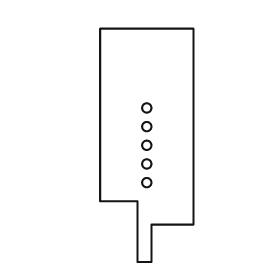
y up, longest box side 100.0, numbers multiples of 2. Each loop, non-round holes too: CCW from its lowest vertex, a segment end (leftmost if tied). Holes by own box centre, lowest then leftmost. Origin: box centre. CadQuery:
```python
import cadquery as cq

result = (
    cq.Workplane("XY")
    .moveTo(-4.0, -50.0)
    .lineTo(2.0, -50.0)
    .lineTo(2.0, -34.0)
    .lineTo(20.0, -34.0)
    .lineTo(20.0, 50.0)
    .lineTo(-20.0, 50.0)
    .lineTo(-20.0, -24.0)
    .lineTo(-4.0, -24.0)
    .close()
    .moveTo(0.0, -16.0)
    .circle(2.0)
    .moveTo(0.0, -8.0)
    .circle(2.0)
    .moveTo(0.0, 0.0)
    .circle(2.0)
    .moveTo(0.0, 8.0)
    .circle(2.0)
    .moveTo(0.0, 16.0)
    .circle(2.0)
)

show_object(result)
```